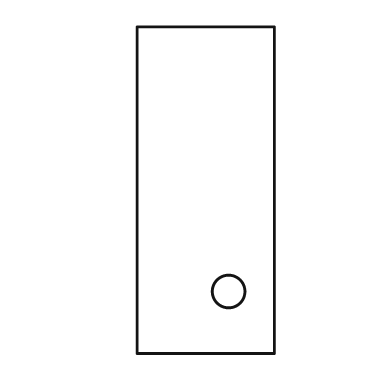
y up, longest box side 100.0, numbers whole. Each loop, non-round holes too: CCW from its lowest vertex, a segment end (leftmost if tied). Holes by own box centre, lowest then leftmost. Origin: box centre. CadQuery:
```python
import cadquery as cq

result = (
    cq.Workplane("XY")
    .moveTo(-21.0, -50.0)
    .lineTo(21.0, -50.0)
    .lineTo(21.0, 50.0)
    .lineTo(-21.0, 50.0)
    .close()
    .moveTo(7.0, -31.0)
    .circle(5.0)
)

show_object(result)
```